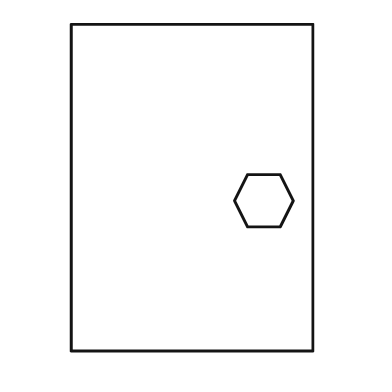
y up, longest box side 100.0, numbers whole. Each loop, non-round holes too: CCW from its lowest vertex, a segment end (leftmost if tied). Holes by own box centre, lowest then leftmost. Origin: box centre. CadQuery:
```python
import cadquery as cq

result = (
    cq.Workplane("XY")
    .moveTo(-37.0, -50.0)
    .lineTo(37.0, -50.0)
    .lineTo(37.0, 50.0)
    .lineTo(-37.0, 50.0)
    .close()
    .moveTo(17.0, -12.0)
    .lineTo(27.0, -12.0)
    .lineTo(31.0, -4.0)
    .lineTo(27.0, 4.0)
    .lineTo(17.0, 4.0)
    .lineTo(13.0, -4.0)
    .close()
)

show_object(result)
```